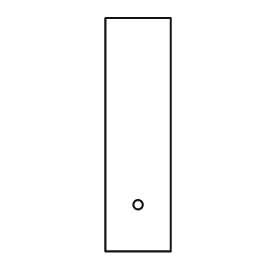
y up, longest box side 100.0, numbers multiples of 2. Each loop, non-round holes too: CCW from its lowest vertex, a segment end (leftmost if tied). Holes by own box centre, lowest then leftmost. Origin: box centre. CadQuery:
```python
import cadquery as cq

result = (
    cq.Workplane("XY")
    .moveTo(-14.0, -50.0)
    .lineTo(14.0, -50.0)
    .lineTo(14.0, 50.0)
    .lineTo(-14.0, 50.0)
    .close()
    .moveTo(0.0, -30.0)
    .circle(2.0)
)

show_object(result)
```